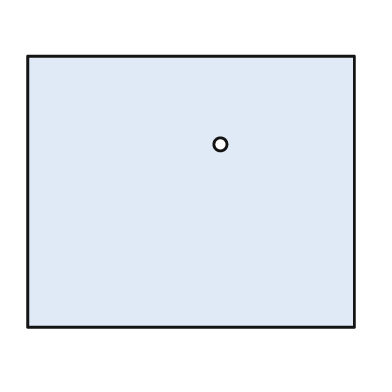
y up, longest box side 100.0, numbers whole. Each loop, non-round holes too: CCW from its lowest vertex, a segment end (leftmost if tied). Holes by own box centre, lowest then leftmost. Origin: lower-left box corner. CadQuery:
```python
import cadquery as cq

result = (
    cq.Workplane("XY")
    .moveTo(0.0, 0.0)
    .lineTo(100.0, 0.0)
    .lineTo(100.0, 83.0)
    .lineTo(0.0, 83.0)
    .close()
    .moveTo(59.0, 56.0)
    .circle(2.0)
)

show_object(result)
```